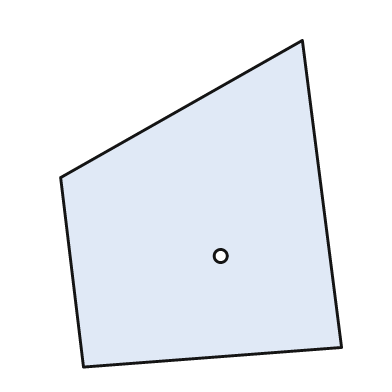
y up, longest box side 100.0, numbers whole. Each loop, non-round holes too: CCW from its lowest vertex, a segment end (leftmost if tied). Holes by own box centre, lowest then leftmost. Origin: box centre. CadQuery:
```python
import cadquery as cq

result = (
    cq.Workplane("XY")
    .moveTo(-36.0, -50.0)
    .lineTo(43.0, -44.0)
    .lineTo(31.0, 50.0)
    .lineTo(-43.0, 8.0)
    .close()
    .moveTo(6.0, -16.0)
    .circle(2.0)
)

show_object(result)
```